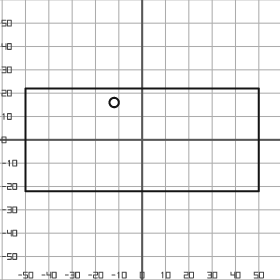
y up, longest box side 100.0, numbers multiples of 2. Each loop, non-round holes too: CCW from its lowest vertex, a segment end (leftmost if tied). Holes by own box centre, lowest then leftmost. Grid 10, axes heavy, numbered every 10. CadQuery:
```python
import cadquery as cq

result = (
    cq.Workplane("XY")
    .moveTo(-50.0, -22.0)
    .lineTo(50.0, -22.0)
    .lineTo(50.0, 22.0)
    .lineTo(-50.0, 22.0)
    .close()
    .moveTo(-12.0, 16.0)
    .circle(2.0)
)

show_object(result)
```